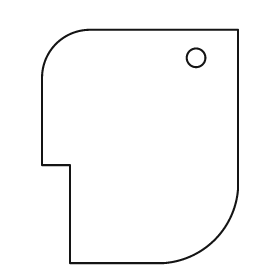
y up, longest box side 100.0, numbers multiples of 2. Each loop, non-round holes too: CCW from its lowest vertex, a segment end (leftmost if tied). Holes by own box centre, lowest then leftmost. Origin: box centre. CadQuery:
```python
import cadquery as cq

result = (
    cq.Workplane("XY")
    .moveTo(-30.0, -50.0)
    .lineTo(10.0, -50.0)
    .threePointArc((32.0, -40.0), (42.0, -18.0))
    .lineTo(42.0, 50.0)
    .lineTo(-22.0, 50.0)
    .threePointArc((-36.0, 44.0), (-42.0, 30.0))
    .lineTo(-42.0, -8.0)
    .lineTo(-30.0, -8.0)
    .close()
    .moveTo(24.0, 38.0)
    .circle(4.0)
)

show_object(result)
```